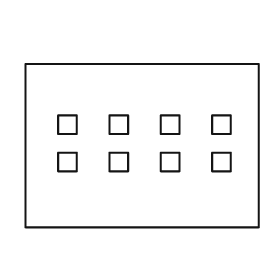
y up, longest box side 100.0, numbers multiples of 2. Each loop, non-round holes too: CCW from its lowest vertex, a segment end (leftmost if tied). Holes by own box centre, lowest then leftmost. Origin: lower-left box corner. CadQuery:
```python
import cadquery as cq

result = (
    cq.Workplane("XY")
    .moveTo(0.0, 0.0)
    .lineTo(100.0, 0.0)
    .lineTo(100.0, 70.0)
    .lineTo(0.0, 70.0)
    .close()
    .moveTo(14.0, 24.0)
    .lineTo(22.0, 24.0)
    .lineTo(22.0, 32.0)
    .lineTo(14.0, 32.0)
    .close()
    .moveTo(36.0, 24.0)
    .lineTo(44.0, 24.0)
    .lineTo(44.0, 32.0)
    .lineTo(36.0, 32.0)
    .close()
    .moveTo(58.0, 24.0)
    .lineTo(66.0, 24.0)
    .lineTo(66.0, 32.0)
    .lineTo(58.0, 32.0)
    .close()
    .moveTo(80.0, 24.0)
    .lineTo(88.0, 24.0)
    .lineTo(88.0, 32.0)
    .lineTo(80.0, 32.0)
    .close()
    .moveTo(14.0, 40.0)
    .lineTo(22.0, 40.0)
    .lineTo(22.0, 48.0)
    .lineTo(14.0, 48.0)
    .close()
    .moveTo(36.0, 40.0)
    .lineTo(44.0, 40.0)
    .lineTo(44.0, 48.0)
    .lineTo(36.0, 48.0)
    .close()
    .moveTo(58.0, 40.0)
    .lineTo(66.0, 40.0)
    .lineTo(66.0, 48.0)
    .lineTo(58.0, 48.0)
    .close()
    .moveTo(80.0, 40.0)
    .lineTo(88.0, 40.0)
    .lineTo(88.0, 48.0)
    .lineTo(80.0, 48.0)
    .close()
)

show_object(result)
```